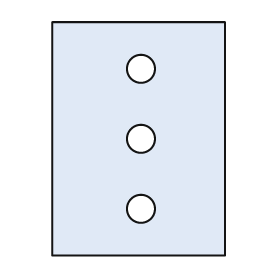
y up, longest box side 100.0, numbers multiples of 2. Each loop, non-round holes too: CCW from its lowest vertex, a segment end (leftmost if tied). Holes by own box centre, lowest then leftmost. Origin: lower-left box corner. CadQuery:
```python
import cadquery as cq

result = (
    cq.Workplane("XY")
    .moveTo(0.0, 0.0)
    .lineTo(74.0, 0.0)
    .lineTo(74.0, 100.0)
    .lineTo(0.0, 100.0)
    .close()
    .moveTo(38.0, 20.0)
    .circle(6.0)
    .moveTo(38.0, 50.0)
    .circle(6.0)
    .moveTo(38.0, 80.0)
    .circle(6.0)
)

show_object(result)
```